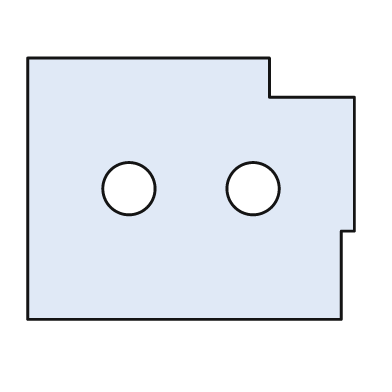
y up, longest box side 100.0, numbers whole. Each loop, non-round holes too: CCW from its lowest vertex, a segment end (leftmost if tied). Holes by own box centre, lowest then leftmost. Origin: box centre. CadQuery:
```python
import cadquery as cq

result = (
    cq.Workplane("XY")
    .moveTo(-50.0, -40.0)
    .lineTo(46.0, -40.0)
    .lineTo(46.0, -13.0)
    .lineTo(50.0, -13.0)
    .lineTo(50.0, 28.0)
    .lineTo(24.0, 28.0)
    .lineTo(24.0, 40.0)
    .lineTo(-50.0, 40.0)
    .close()
    .moveTo(-19.0, 0.0)
    .circle(8.0)
    .moveTo(19.0, 0.0)
    .circle(8.0)
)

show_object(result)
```